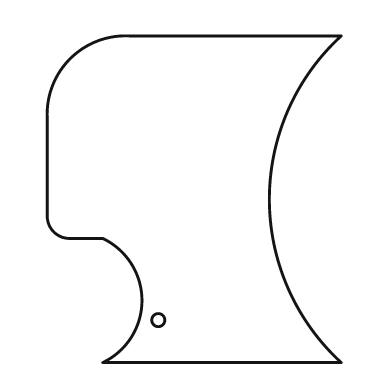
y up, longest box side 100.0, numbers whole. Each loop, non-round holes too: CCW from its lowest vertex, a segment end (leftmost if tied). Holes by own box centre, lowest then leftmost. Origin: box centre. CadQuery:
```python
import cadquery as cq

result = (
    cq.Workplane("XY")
    .moveTo(-28.0, -50.0)
    .lineTo(45.0, -50.0)
    .threePointArc((23.0, 0.0), (45.0, 50.0))
    .lineTo(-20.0, 50.0)
    .threePointArc((-38.0, 43.0), (-45.0, 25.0))
    .lineTo(-45.0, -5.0)
    .threePointArc((-43.0, -10.0), (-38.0, -12.0))
    .lineTo(-28.0, -12.0)
    .threePointArc((-16.0, -31.0), (-28.0, -50.0))
    .close()
    .moveTo(-11.0, -37.0)
    .circle(2.0)
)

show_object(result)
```